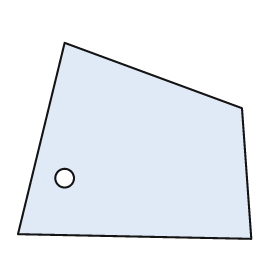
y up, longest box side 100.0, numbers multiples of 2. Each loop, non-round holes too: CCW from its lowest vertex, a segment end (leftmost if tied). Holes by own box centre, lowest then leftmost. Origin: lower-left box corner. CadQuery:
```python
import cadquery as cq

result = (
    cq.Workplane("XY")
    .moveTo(100.0, 0.0)
    .lineTo(96.0, 56.0)
    .lineTo(20.0, 84.0)
    .lineTo(0.0, 2.0)
    .close()
    .moveTo(20.0, 26.0)
    .circle(4.0)
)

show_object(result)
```